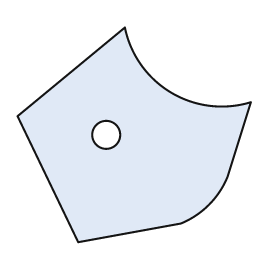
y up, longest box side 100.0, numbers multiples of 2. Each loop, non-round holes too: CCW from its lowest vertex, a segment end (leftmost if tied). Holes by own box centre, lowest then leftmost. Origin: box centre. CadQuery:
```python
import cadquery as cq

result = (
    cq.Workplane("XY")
    .moveTo(-24.0, -46.0)
    .lineTo(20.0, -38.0)
    .threePointArc((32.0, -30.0), (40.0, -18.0))
    .lineTo(50.0, 14.0)
    .threePointArc((16.0, 18.0), (-4.0, 46.0))
    .lineTo(-50.0, 8.0)
    .close()
    .moveTo(-12.0, 0.0)
    .circle(6.0)
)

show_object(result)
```